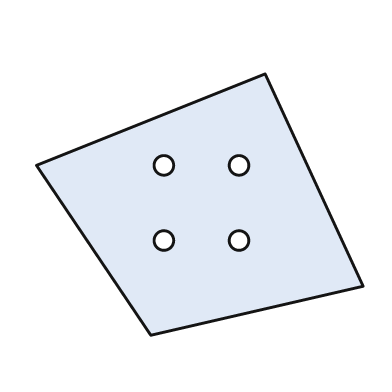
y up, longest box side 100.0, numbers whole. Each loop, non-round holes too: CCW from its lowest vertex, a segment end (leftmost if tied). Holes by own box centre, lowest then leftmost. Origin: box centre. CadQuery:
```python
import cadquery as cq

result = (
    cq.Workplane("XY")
    .moveTo(-15.0, -40.0)
    .lineTo(50.0, -25.0)
    .lineTo(20.0, 40.0)
    .lineTo(-50.0, 12.0)
    .close()
    .moveTo(-11.0, -11.0)
    .circle(3.0)
    .moveTo(12.0, -11.0)
    .circle(3.0)
    .moveTo(-11.0, 12.0)
    .circle(3.0)
    .moveTo(12.0, 12.0)
    .circle(3.0)
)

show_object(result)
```